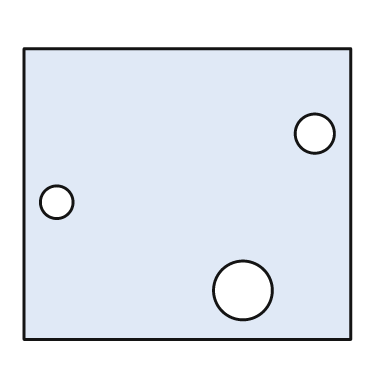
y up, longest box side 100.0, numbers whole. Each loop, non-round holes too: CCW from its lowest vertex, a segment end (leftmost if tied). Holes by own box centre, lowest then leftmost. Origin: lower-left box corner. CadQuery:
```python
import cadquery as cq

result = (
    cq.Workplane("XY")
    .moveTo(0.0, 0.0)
    .lineTo(100.0, 0.0)
    .lineTo(100.0, 89.0)
    .lineTo(0.0, 89.0)
    .close()
    .moveTo(67.0, 15.0)
    .circle(9.0)
    .moveTo(10.0, 42.0)
    .circle(5.0)
    .moveTo(89.0, 63.0)
    .circle(6.0)
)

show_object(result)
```